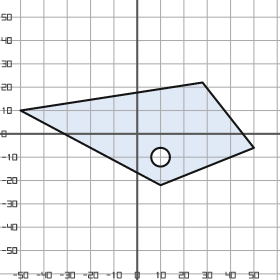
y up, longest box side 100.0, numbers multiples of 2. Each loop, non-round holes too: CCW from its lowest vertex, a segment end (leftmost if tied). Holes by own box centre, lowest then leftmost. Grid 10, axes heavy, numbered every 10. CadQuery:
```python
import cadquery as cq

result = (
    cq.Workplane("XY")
    .moveTo(10.0, -22.0)
    .lineTo(50.0, -6.0)
    .lineTo(28.0, 22.0)
    .lineTo(-50.0, 10.0)
    .close()
    .moveTo(10.0, -10.0)
    .circle(4.0)
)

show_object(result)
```